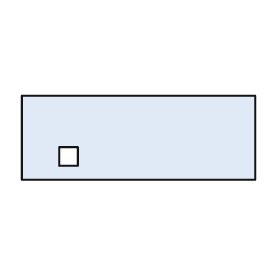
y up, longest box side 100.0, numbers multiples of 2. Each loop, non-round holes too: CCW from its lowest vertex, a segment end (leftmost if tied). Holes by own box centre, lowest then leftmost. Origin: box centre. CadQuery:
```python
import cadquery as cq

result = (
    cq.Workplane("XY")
    .moveTo(-50.0, -18.0)
    .lineTo(50.0, -18.0)
    .lineTo(50.0, 18.0)
    .lineTo(-50.0, 18.0)
    .close()
    .moveTo(-34.0, -12.0)
    .lineTo(-26.0, -12.0)
    .lineTo(-26.0, -4.0)
    .lineTo(-34.0, -4.0)
    .close()
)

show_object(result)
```